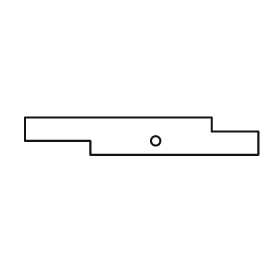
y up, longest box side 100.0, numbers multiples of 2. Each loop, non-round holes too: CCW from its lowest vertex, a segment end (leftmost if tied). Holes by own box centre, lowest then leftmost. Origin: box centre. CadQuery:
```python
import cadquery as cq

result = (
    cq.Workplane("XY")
    .moveTo(-22.0, -8.0)
    .lineTo(50.0, -8.0)
    .lineTo(50.0, 2.0)
    .lineTo(30.0, 2.0)
    .lineTo(30.0, 8.0)
    .lineTo(-50.0, 8.0)
    .lineTo(-50.0, -2.0)
    .lineTo(-22.0, -2.0)
    .close()
    .moveTo(6.0, -2.0)
    .circle(2.0)
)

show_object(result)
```